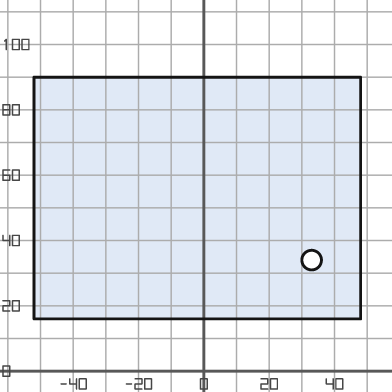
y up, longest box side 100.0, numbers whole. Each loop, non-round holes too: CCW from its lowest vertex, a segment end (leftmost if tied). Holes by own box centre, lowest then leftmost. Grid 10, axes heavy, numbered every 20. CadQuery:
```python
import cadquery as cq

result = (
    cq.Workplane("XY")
    .moveTo(-52.0, 16.0)
    .lineTo(48.0, 16.0)
    .lineTo(48.0, 90.0)
    .lineTo(-52.0, 90.0)
    .close()
    .moveTo(33.0, 34.0)
    .circle(3.0)
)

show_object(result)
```